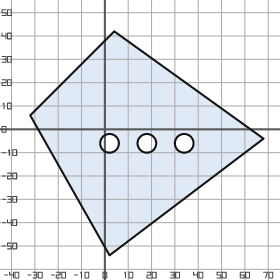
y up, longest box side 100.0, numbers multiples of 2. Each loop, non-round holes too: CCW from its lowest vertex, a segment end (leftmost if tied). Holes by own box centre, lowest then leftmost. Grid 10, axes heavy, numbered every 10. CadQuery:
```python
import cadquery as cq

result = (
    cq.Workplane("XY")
    .moveTo(2.0, -54.0)
    .lineTo(68.0, -4.0)
    .lineTo(4.0, 42.0)
    .lineTo(-32.0, 6.0)
    .close()
    .moveTo(2.0, -6.0)
    .circle(4.0)
    .moveTo(18.0, -6.0)
    .circle(4.0)
    .moveTo(34.0, -6.0)
    .circle(4.0)
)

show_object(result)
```